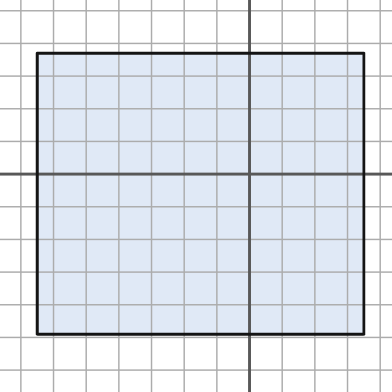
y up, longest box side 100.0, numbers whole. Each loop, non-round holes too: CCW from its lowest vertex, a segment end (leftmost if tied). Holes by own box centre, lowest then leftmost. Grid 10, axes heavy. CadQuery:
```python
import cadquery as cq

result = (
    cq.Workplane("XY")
    .moveTo(-65.0, -49.0)
    .lineTo(35.0, -49.0)
    .lineTo(35.0, 37.0)
    .lineTo(-65.0, 37.0)
    .close()
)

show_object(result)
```